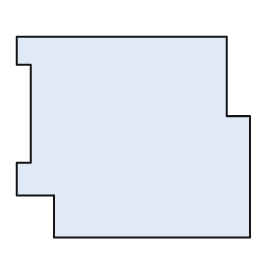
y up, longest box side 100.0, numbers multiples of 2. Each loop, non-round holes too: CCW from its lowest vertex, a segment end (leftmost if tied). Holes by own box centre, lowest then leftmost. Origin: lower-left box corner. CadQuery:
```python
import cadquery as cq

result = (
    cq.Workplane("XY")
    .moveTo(16.0, 0.0)
    .lineTo(100.0, 0.0)
    .lineTo(100.0, 52.0)
    .lineTo(90.0, 52.0)
    .lineTo(90.0, 86.0)
    .lineTo(0.0, 86.0)
    .lineTo(0.0, 74.0)
    .lineTo(6.0, 74.0)
    .lineTo(6.0, 32.0)
    .lineTo(0.0, 32.0)
    .lineTo(0.0, 18.0)
    .lineTo(16.0, 18.0)
    .close()
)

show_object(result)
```